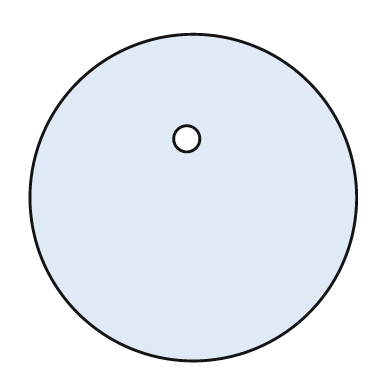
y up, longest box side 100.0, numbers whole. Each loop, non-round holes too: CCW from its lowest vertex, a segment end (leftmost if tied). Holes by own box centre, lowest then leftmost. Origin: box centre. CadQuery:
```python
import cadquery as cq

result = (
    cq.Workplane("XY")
    .moveTo(0.0, 0.0)
    .circle(50.0)
    .moveTo(-2.0, 18.0)
    .circle(4.0)
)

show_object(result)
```